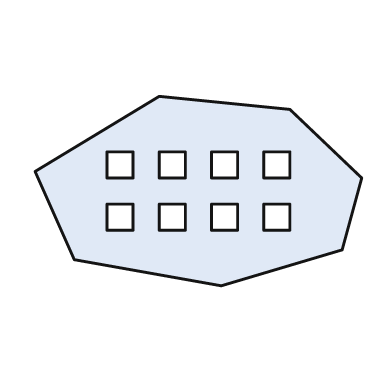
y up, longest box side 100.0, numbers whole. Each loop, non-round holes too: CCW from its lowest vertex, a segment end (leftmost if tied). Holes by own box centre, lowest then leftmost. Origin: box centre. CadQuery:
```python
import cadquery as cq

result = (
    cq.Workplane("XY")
    .moveTo(7.0, -29.0)
    .lineTo(44.0, -18.0)
    .lineTo(50.0, 4.0)
    .lineTo(28.0, 25.0)
    .lineTo(-12.0, 29.0)
    .lineTo(-50.0, 6.0)
    .lineTo(-38.0, -21.0)
    .close()
    .moveTo(-28.0, -12.0)
    .lineTo(-20.0, -12.0)
    .lineTo(-20.0, -4.0)
    .lineTo(-28.0, -4.0)
    .close()
    .moveTo(-12.0, -12.0)
    .lineTo(-4.0, -12.0)
    .lineTo(-4.0, -4.0)
    .lineTo(-12.0, -4.0)
    .close()
    .moveTo(4.0, -12.0)
    .lineTo(12.0, -12.0)
    .lineTo(12.0, -4.0)
    .lineTo(4.0, -4.0)
    .close()
    .moveTo(20.0, -12.0)
    .lineTo(28.0, -12.0)
    .lineTo(28.0, -4.0)
    .lineTo(20.0, -4.0)
    .close()
    .moveTo(-28.0, 4.0)
    .lineTo(-20.0, 4.0)
    .lineTo(-20.0, 12.0)
    .lineTo(-28.0, 12.0)
    .close()
    .moveTo(-12.0, 4.0)
    .lineTo(-4.0, 4.0)
    .lineTo(-4.0, 12.0)
    .lineTo(-12.0, 12.0)
    .close()
    .moveTo(4.0, 4.0)
    .lineTo(12.0, 4.0)
    .lineTo(12.0, 12.0)
    .lineTo(4.0, 12.0)
    .close()
    .moveTo(20.0, 4.0)
    .lineTo(28.0, 4.0)
    .lineTo(28.0, 12.0)
    .lineTo(20.0, 12.0)
    .close()
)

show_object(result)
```